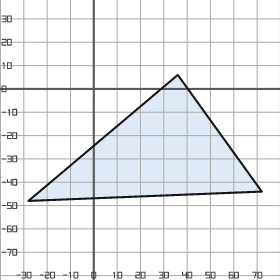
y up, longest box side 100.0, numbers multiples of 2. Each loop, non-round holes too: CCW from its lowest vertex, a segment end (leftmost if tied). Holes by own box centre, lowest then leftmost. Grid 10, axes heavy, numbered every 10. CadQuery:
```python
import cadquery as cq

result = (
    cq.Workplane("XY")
    .moveTo(-28.0, -48.0)
    .lineTo(72.0, -44.0)
    .lineTo(36.0, 6.0)
    .close()
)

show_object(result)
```